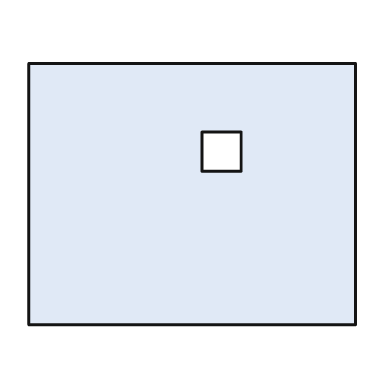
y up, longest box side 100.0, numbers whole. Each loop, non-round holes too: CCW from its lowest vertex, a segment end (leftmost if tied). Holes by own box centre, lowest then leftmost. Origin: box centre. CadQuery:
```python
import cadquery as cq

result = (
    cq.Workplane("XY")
    .moveTo(-50.0, -40.0)
    .lineTo(50.0, -40.0)
    .lineTo(50.0, 40.0)
    .lineTo(-50.0, 40.0)
    .close()
    .moveTo(3.0, 7.0)
    .lineTo(15.0, 7.0)
    .lineTo(15.0, 19.0)
    .lineTo(3.0, 19.0)
    .close()
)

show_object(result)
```